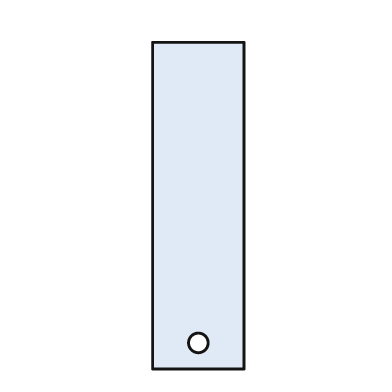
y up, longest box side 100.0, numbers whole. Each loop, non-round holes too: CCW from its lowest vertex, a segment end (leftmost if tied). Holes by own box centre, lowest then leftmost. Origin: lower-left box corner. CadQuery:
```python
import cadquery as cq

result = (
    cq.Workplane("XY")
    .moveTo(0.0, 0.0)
    .lineTo(28.0, 0.0)
    .lineTo(28.0, 100.0)
    .lineTo(0.0, 100.0)
    .close()
    .moveTo(14.0, 8.0)
    .circle(3.0)
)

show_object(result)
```